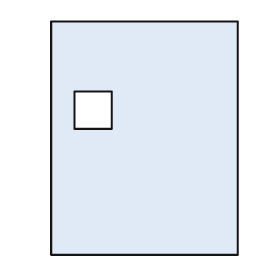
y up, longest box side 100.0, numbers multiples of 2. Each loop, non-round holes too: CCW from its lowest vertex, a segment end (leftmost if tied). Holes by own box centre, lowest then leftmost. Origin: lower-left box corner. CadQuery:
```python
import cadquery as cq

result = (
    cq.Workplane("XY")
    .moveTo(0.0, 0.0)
    .lineTo(80.0, 0.0)
    .lineTo(80.0, 100.0)
    .lineTo(0.0, 100.0)
    .close()
    .moveTo(10.0, 54.0)
    .lineTo(26.0, 54.0)
    .lineTo(26.0, 70.0)
    .lineTo(10.0, 70.0)
    .close()
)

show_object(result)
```